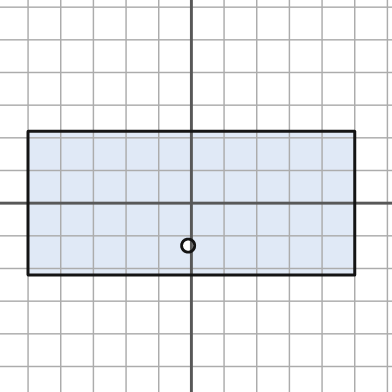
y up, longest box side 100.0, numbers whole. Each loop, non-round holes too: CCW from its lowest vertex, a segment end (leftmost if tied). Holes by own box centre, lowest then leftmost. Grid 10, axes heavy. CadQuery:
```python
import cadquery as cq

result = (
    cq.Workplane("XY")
    .moveTo(-50.0, -22.0)
    .lineTo(50.0, -22.0)
    .lineTo(50.0, 22.0)
    .lineTo(-50.0, 22.0)
    .close()
    .moveTo(-1.0, -13.0)
    .circle(2.0)
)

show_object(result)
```